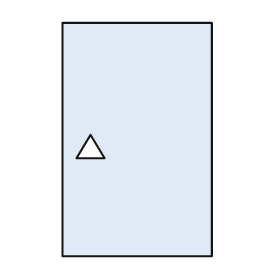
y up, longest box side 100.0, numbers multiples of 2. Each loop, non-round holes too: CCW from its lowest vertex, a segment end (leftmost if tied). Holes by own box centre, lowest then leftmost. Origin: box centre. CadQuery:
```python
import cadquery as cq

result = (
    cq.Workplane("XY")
    .moveTo(-32.0, -50.0)
    .lineTo(32.0, -50.0)
    .lineTo(32.0, 50.0)
    .lineTo(-32.0, 50.0)
    .close()
    .moveTo(-26.0, -8.0)
    .lineTo(-14.0, -8.0)
    .lineTo(-20.0, 2.0)
    .close()
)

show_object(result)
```